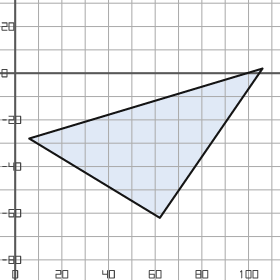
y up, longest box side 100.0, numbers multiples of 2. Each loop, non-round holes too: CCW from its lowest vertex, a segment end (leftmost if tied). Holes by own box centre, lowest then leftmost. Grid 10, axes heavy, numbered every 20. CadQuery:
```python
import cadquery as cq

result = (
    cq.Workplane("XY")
    .moveTo(62.0, -62.0)
    .lineTo(106.0, 2.0)
    .lineTo(6.0, -28.0)
    .close()
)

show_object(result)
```